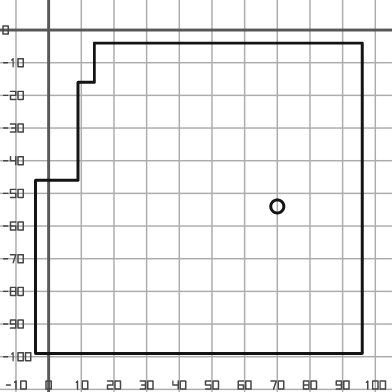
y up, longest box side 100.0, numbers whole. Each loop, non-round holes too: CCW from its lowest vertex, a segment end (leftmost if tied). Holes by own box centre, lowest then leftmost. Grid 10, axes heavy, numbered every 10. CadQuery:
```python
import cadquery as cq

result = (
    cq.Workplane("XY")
    .moveTo(-4.0, -99.0)
    .lineTo(96.0, -99.0)
    .lineTo(96.0, -4.0)
    .lineTo(14.0, -4.0)
    .lineTo(14.0, -16.0)
    .lineTo(9.0, -16.0)
    .lineTo(9.0, -46.0)
    .lineTo(-4.0, -46.0)
    .close()
    .moveTo(70.0, -54.0)
    .circle(2.0)
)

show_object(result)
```